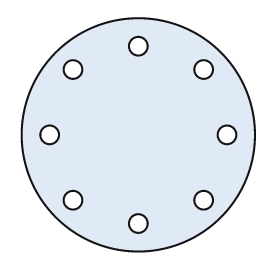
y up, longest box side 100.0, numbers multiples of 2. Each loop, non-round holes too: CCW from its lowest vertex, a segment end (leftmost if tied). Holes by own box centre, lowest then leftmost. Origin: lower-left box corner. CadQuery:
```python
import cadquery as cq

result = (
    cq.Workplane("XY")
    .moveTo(50.0, 50.0)
    .circle(50.0)
    .moveTo(50.0, 12.0)
    .circle(4.0)
    .moveTo(22.0, 22.0)
    .circle(4.0)
    .moveTo(78.0, 22.0)
    .circle(4.0)
    .moveTo(12.0, 50.0)
    .circle(4.0)
    .moveTo(88.0, 50.0)
    .circle(4.0)
    .moveTo(22.0, 78.0)
    .circle(4.0)
    .moveTo(78.0, 78.0)
    .circle(4.0)
    .moveTo(50.0, 88.0)
    .circle(4.0)
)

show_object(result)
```